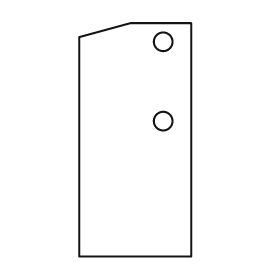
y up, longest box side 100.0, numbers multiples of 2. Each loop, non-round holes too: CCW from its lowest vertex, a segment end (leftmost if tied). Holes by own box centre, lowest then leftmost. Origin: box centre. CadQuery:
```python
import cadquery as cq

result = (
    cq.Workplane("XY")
    .moveTo(-24.0, -50.0)
    .lineTo(24.0, -50.0)
    .lineTo(24.0, 50.0)
    .lineTo(-2.0, 50.0)
    .lineTo(-24.0, 44.0)
    .close()
    .moveTo(12.0, 8.0)
    .circle(4.0)
    .moveTo(12.0, 42.0)
    .circle(4.0)
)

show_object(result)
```